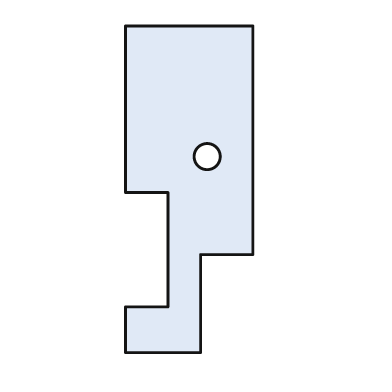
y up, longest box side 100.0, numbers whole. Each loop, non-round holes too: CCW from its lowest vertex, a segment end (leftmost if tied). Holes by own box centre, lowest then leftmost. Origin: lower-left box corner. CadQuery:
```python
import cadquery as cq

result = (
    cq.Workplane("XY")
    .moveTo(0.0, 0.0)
    .lineTo(23.0, 0.0)
    .lineTo(23.0, 30.0)
    .lineTo(39.0, 30.0)
    .lineTo(39.0, 100.0)
    .lineTo(0.0, 100.0)
    .lineTo(0.0, 49.0)
    .lineTo(13.0, 49.0)
    .lineTo(13.0, 14.0)
    .lineTo(0.0, 14.0)
    .close()
    .moveTo(25.0, 60.0)
    .circle(4.0)
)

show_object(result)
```